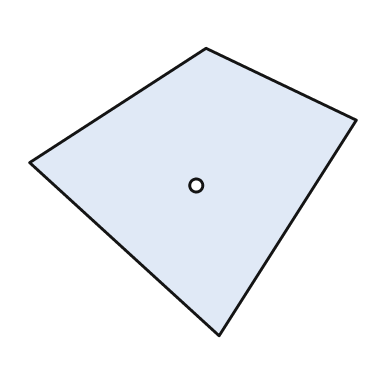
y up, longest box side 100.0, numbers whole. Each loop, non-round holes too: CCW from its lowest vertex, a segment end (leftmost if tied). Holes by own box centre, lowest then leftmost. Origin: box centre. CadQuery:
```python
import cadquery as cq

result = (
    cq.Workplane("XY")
    .moveTo(8.0, -44.0)
    .lineTo(50.0, 22.0)
    .lineTo(4.0, 44.0)
    .lineTo(-50.0, 9.0)
    .close()
    .moveTo(1.0, 2.0)
    .circle(2.0)
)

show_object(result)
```